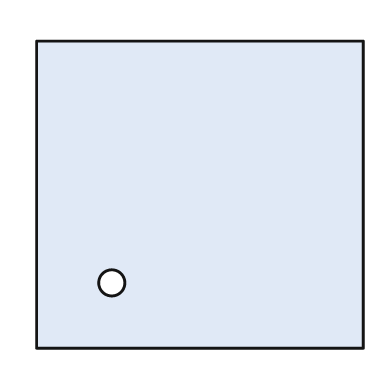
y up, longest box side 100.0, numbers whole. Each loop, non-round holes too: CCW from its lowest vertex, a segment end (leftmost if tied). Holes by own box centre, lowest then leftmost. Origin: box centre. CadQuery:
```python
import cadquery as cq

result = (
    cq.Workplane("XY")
    .moveTo(-50.0, -47.0)
    .lineTo(50.0, -47.0)
    .lineTo(50.0, 47.0)
    .lineTo(-50.0, 47.0)
    .close()
    .moveTo(-27.0, -27.0)
    .circle(4.0)
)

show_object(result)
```